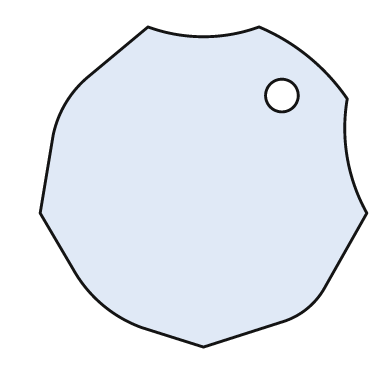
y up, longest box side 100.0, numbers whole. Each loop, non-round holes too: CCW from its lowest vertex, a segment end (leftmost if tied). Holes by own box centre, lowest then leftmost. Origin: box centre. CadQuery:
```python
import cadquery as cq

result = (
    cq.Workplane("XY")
    .moveTo(0.0, -49.0)
    .lineTo(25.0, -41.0)
    .threePointArc((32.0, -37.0), (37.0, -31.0))
    .lineTo(50.0, -8.0)
    .threePointArc((44.0, 9.0), (44.0, 27.0))
    .threePointArc((32.0, 40.0), (17.0, 49.0))
    .threePointArc((0.0, 46.0), (-17.0, 49.0))
    .lineTo(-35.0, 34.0)
    .threePointArc((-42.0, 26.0), (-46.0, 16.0))
    .lineTo(-50.0, -8.0)
    .lineTo(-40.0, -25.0)
    .threePointArc((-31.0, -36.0), (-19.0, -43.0))
    .close()
    .moveTo(24.0, 28.0)
    .circle(5.0)
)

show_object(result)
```